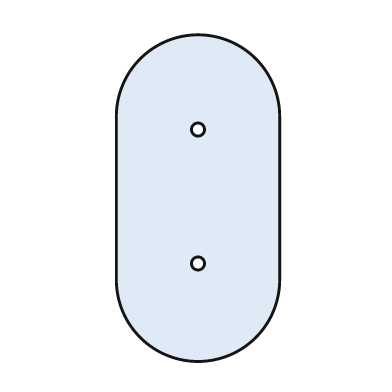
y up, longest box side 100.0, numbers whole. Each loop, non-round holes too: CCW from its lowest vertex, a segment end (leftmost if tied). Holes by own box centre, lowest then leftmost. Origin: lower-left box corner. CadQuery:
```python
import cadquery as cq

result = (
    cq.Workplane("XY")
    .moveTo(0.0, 25.0)
    .threePointArc((25.0, 0.0), (50.0, 25.0))
    .lineTo(50.0, 75.0)
    .threePointArc((25.0, 100.0), (0.0, 75.0))
    .close()
    .moveTo(25.0, 30.0)
    .circle(2.0)
    .moveTo(25.0, 71.0)
    .circle(2.0)
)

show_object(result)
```